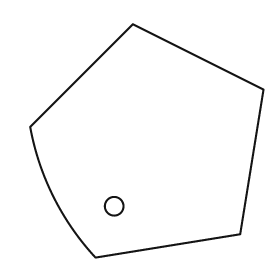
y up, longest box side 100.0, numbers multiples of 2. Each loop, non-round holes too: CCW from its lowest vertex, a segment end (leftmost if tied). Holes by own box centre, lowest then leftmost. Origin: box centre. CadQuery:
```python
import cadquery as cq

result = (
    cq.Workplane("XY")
    .moveTo(-22.0, -50.0)
    .lineTo(40.0, -40.0)
    .lineTo(50.0, 22.0)
    .lineTo(-6.0, 50.0)
    .lineTo(-50.0, 6.0)
    .threePointArc((-40.0, -24.0), (-22.0, -50.0))
    .close()
    .moveTo(-14.0, -28.0)
    .circle(4.0)
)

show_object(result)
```